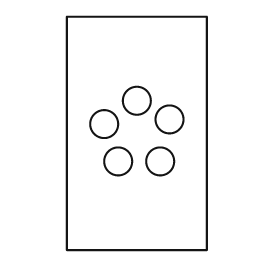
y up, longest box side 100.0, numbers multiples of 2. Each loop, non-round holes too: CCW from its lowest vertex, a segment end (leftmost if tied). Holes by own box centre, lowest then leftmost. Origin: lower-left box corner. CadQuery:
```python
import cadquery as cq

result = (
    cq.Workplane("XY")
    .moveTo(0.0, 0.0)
    .lineTo(60.0, 0.0)
    .lineTo(60.0, 100.0)
    .lineTo(0.0, 100.0)
    .close()
    .moveTo(22.0, 38.0)
    .circle(6.0)
    .moveTo(40.0, 38.0)
    .circle(6.0)
    .moveTo(16.0, 54.0)
    .circle(6.0)
    .moveTo(44.0, 56.0)
    .circle(6.0)
    .moveTo(30.0, 64.0)
    .circle(6.0)
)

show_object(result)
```